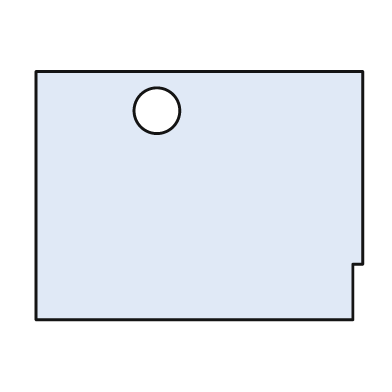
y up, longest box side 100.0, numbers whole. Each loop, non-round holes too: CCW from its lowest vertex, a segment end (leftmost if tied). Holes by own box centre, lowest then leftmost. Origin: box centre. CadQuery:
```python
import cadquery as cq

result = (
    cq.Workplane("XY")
    .moveTo(-50.0, -38.0)
    .lineTo(47.0, -38.0)
    .lineTo(47.0, -21.0)
    .lineTo(50.0, -21.0)
    .lineTo(50.0, 38.0)
    .lineTo(-50.0, 38.0)
    .close()
    .moveTo(-13.0, 26.0)
    .circle(7.0)
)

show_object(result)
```